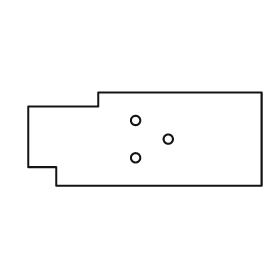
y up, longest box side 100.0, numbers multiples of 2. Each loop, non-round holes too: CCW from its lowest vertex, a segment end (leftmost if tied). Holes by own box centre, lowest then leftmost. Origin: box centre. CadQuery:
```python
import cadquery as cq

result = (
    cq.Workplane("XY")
    .moveTo(-38.0, -20.0)
    .lineTo(50.0, -20.0)
    .lineTo(50.0, 20.0)
    .lineTo(-20.0, 20.0)
    .lineTo(-20.0, 14.0)
    .lineTo(-50.0, 14.0)
    .lineTo(-50.0, -12.0)
    .lineTo(-38.0, -12.0)
    .close()
    .moveTo(-4.0, -8.0)
    .circle(2.0)
    .moveTo(10.0, 0.0)
    .circle(2.0)
    .moveTo(-4.0, 8.0)
    .circle(2.0)
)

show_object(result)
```